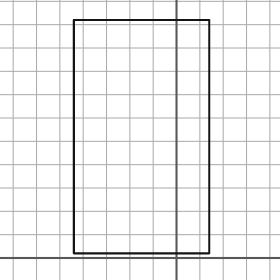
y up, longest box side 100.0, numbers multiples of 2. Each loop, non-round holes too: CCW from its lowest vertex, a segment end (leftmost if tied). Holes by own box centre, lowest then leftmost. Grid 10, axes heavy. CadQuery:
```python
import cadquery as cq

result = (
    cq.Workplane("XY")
    .moveTo(-44.0, 2.0)
    .lineTo(14.0, 2.0)
    .lineTo(14.0, 102.0)
    .lineTo(-44.0, 102.0)
    .close()
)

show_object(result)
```